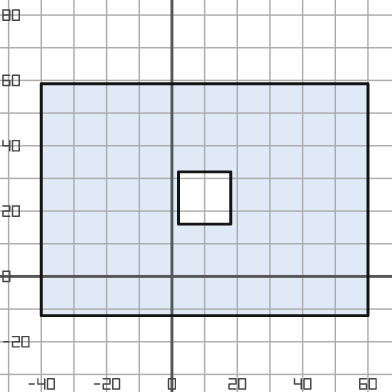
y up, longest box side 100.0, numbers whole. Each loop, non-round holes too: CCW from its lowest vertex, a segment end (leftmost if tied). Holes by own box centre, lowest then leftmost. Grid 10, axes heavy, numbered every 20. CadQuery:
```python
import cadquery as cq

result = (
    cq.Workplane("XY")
    .moveTo(-40.0, -12.0)
    .lineTo(60.0, -12.0)
    .lineTo(60.0, 59.0)
    .lineTo(-40.0, 59.0)
    .close()
    .moveTo(2.0, 16.0)
    .lineTo(18.0, 16.0)
    .lineTo(18.0, 32.0)
    .lineTo(2.0, 32.0)
    .close()
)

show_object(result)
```